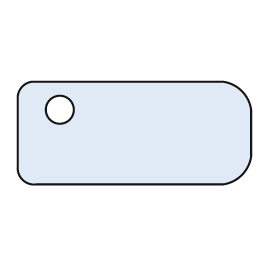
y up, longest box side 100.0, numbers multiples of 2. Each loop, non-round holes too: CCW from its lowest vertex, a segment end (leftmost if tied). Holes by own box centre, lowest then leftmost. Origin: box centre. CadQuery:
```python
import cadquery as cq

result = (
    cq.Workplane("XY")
    .moveTo(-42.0, -22.0)
    .lineTo(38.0, -22.0)
    .threePointArc((46.0, -18.0), (50.0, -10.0))
    .lineTo(50.0, 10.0)
    .threePointArc((46.0, 18.0), (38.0, 22.0))
    .lineTo(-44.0, 22.0)
    .threePointArc((-48.0, 20.0), (-50.0, 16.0))
    .lineTo(-50.0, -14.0)
    .threePointArc((-48.0, -20.0), (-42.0, -22.0))
    .close()
    .moveTo(-32.0, 10.0)
    .circle(6.0)
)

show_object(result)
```